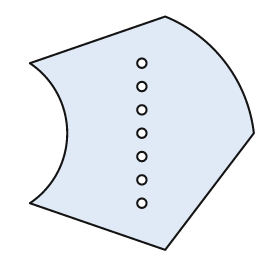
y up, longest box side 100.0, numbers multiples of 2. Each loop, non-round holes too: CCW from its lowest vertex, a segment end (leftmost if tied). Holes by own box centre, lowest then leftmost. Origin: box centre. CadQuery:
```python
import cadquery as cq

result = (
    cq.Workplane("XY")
    .moveTo(10.0, -50.0)
    .lineTo(48.0, 0.0)
    .threePointArc((36.0, 30.0), (10.0, 50.0))
    .lineTo(-48.0, 30.0)
    .threePointArc((-32.0, 0.0), (-48.0, -30.0))
    .close()
    .moveTo(0.0, -30.0)
    .circle(2.0)
    .moveTo(0.0, -20.0)
    .circle(2.0)
    .moveTo(0.0, -10.0)
    .circle(2.0)
    .moveTo(0.0, 0.0)
    .circle(2.0)
    .moveTo(0.0, 10.0)
    .circle(2.0)
    .moveTo(0.0, 20.0)
    .circle(2.0)
    .moveTo(0.0, 30.0)
    .circle(2.0)
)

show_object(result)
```